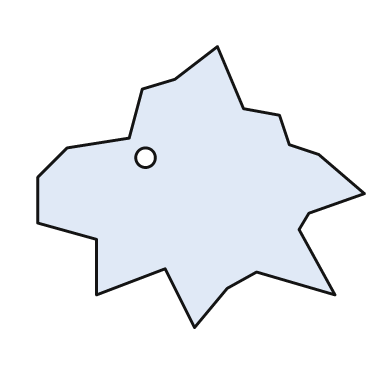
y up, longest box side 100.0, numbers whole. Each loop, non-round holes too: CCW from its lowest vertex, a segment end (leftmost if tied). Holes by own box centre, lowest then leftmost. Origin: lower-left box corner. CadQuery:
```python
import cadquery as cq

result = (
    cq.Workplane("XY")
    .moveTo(48.0, 0.0)
    .lineTo(58.0, 12.0)
    .lineTo(67.0, 17.0)
    .lineTo(91.0, 10.0)
    .lineTo(80.0, 30.0)
    .lineTo(83.0, 35.0)
    .lineTo(100.0, 41.0)
    .lineTo(86.0, 53.0)
    .lineTo(77.0, 56.0)
    .lineTo(74.0, 65.0)
    .lineTo(63.0, 67.0)
    .lineTo(55.0, 86.0)
    .lineTo(42.0, 76.0)
    .lineTo(32.0, 73.0)
    .lineTo(28.0, 58.0)
    .lineTo(9.0, 55.0)
    .lineTo(0.0, 46.0)
    .lineTo(0.0, 32.0)
    .lineTo(18.0, 27.0)
    .lineTo(18.0, 10.0)
    .lineTo(39.0, 18.0)
    .close()
    .moveTo(33.0, 52.0)
    .circle(3.0)
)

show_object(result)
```